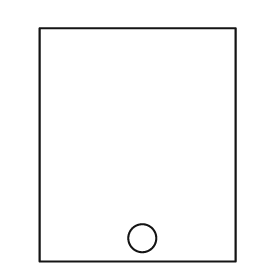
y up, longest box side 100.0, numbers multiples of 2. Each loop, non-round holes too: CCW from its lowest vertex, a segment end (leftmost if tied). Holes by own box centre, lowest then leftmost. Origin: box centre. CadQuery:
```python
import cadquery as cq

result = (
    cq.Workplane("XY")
    .moveTo(-42.0, -50.0)
    .lineTo(42.0, -50.0)
    .lineTo(42.0, 50.0)
    .lineTo(-42.0, 50.0)
    .close()
    .moveTo(2.0, -40.0)
    .circle(6.0)
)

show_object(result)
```